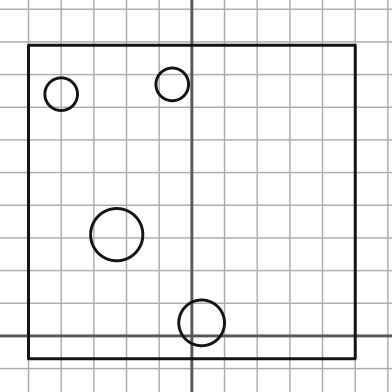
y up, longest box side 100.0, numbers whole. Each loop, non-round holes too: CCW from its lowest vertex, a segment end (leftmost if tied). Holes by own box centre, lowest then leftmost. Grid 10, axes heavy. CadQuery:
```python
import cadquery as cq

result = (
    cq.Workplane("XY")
    .moveTo(-50.0, -7.0)
    .lineTo(50.0, -7.0)
    .lineTo(50.0, 89.0)
    .lineTo(-50.0, 89.0)
    .close()
    .moveTo(3.0, 4.0)
    .circle(7.0)
    .moveTo(-23.0, 31.0)
    .circle(8.0)
    .moveTo(-40.0, 74.0)
    .circle(5.0)
    .moveTo(-6.0, 77.0)
    .circle(5.0)
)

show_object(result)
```